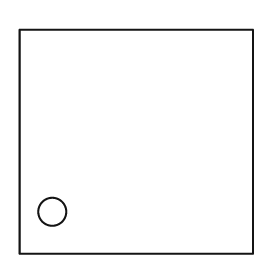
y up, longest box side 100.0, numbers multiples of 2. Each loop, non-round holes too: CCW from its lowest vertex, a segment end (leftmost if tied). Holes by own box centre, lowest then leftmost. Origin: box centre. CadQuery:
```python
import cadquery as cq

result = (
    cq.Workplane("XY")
    .moveTo(-50.0, -48.0)
    .lineTo(50.0, -48.0)
    .lineTo(50.0, 48.0)
    .lineTo(-50.0, 48.0)
    .close()
    .moveTo(-36.0, -30.0)
    .circle(6.0)
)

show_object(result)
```